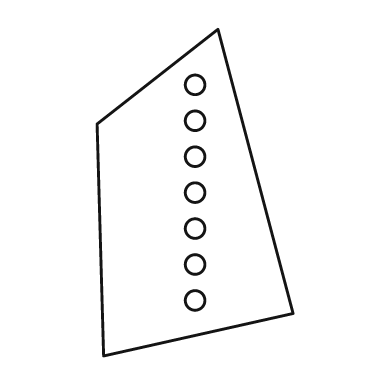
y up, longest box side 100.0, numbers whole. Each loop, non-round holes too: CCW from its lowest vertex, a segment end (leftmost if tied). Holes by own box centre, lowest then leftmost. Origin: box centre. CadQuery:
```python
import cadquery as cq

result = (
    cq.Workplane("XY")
    .moveTo(-28.0, -50.0)
    .lineTo(30.0, -37.0)
    .lineTo(7.0, 50.0)
    .lineTo(-30.0, 21.0)
    .close()
    .moveTo(0.0, -33.0)
    .circle(3.0)
    .moveTo(0.0, -22.0)
    .circle(3.0)
    .moveTo(0.0, -11.0)
    .circle(3.0)
    .moveTo(0.0, 0.0)
    .circle(3.0)
    .moveTo(0.0, 11.0)
    .circle(3.0)
    .moveTo(0.0, 22.0)
    .circle(3.0)
    .moveTo(0.0, 33.0)
    .circle(3.0)
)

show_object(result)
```